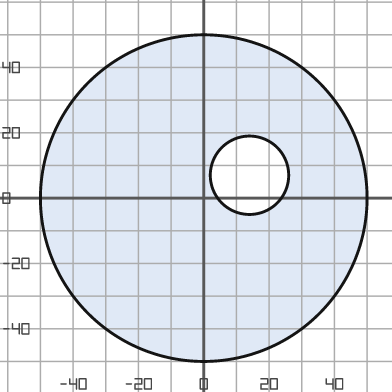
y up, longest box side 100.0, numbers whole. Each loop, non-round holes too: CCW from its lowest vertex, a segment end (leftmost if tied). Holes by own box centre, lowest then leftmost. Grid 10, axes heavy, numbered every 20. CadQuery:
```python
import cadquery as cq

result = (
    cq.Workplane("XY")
    .moveTo(0.0, 0.0)
    .circle(50.0)
    .moveTo(14.0, 7.0)
    .circle(12.0)
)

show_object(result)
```